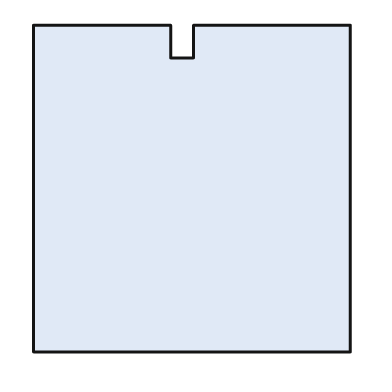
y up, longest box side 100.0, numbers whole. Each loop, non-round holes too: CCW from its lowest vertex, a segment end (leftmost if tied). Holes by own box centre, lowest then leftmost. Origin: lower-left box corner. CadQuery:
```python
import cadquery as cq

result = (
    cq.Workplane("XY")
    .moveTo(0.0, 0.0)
    .lineTo(97.0, 0.0)
    .lineTo(97.0, 100.0)
    .lineTo(49.0, 100.0)
    .lineTo(49.0, 90.0)
    .lineTo(42.0, 90.0)
    .lineTo(42.0, 100.0)
    .lineTo(0.0, 100.0)
    .close()
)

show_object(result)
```